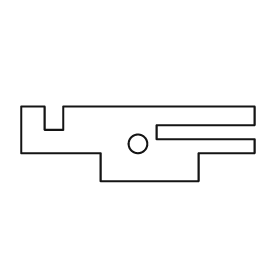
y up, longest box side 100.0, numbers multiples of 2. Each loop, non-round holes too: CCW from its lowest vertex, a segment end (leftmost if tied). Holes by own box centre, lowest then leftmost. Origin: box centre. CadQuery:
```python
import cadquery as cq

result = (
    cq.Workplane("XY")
    .moveTo(-16.0, -16.0)
    .lineTo(26.0, -16.0)
    .lineTo(26.0, -4.0)
    .lineTo(50.0, -4.0)
    .lineTo(50.0, 2.0)
    .lineTo(8.0, 2.0)
    .lineTo(8.0, 8.0)
    .lineTo(50.0, 8.0)
    .lineTo(50.0, 16.0)
    .lineTo(-32.0, 16.0)
    .lineTo(-32.0, 6.0)
    .lineTo(-40.0, 6.0)
    .lineTo(-40.0, 16.0)
    .lineTo(-50.0, 16.0)
    .lineTo(-50.0, -4.0)
    .lineTo(-16.0, -4.0)
    .close()
    .moveTo(0.0, 0.0)
    .circle(4.0)
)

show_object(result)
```